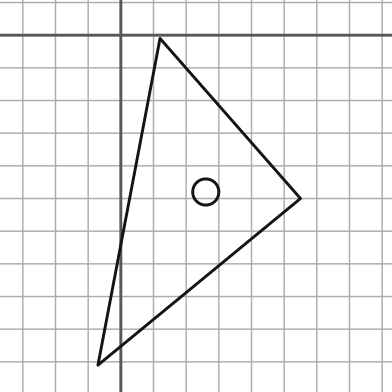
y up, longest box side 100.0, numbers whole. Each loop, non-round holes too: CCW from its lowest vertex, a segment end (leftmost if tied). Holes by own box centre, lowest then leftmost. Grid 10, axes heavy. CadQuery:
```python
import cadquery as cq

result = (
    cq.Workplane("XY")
    .moveTo(-7.0, -101.0)
    .lineTo(55.0, -50.0)
    .lineTo(12.0, -1.0)
    .close()
    .moveTo(26.0, -48.0)
    .circle(4.0)
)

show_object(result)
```